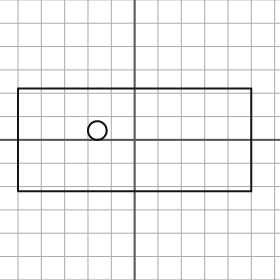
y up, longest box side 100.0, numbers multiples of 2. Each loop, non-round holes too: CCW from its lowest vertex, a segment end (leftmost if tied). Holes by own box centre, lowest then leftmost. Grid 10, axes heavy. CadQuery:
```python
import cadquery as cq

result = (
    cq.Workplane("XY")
    .moveTo(-50.0, -22.0)
    .lineTo(50.0, -22.0)
    .lineTo(50.0, 22.0)
    .lineTo(-50.0, 22.0)
    .close()
    .moveTo(-16.0, 4.0)
    .circle(4.0)
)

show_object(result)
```